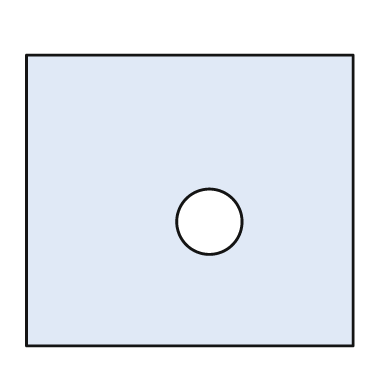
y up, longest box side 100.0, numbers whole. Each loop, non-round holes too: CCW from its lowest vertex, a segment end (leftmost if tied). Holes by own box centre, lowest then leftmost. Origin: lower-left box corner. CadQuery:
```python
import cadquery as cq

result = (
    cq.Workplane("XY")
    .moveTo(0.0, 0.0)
    .lineTo(100.0, 0.0)
    .lineTo(100.0, 89.0)
    .lineTo(0.0, 89.0)
    .close()
    .moveTo(56.0, 38.0)
    .circle(10.0)
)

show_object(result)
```